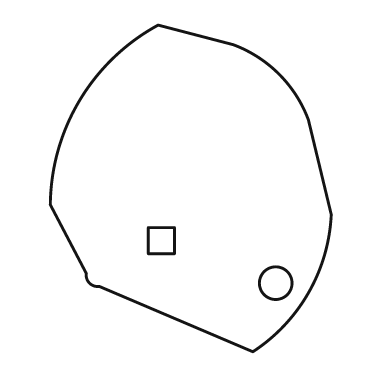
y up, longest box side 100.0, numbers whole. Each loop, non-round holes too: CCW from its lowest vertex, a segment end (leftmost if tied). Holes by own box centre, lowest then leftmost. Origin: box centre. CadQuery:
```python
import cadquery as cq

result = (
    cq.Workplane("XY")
    .moveTo(19.0, -50.0)
    .threePointArc((36.0, -32.0), (43.0, -8.0))
    .lineTo(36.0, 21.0)
    .threePointArc((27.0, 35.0), (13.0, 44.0))
    .lineTo(-10.0, 50.0)
    .threePointArc((-34.0, 27.0), (-43.0, -5.0))
    .lineTo(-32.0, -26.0)
    .threePointArc((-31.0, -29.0), (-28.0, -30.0))
    .close()
    .moveTo(26.0, -29.0)
    .circle(5.0)
    .moveTo(-13.0, -20.0)
    .lineTo(-5.0, -20.0)
    .lineTo(-5.0, -12.0)
    .lineTo(-13.0, -12.0)
    .close()
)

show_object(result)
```